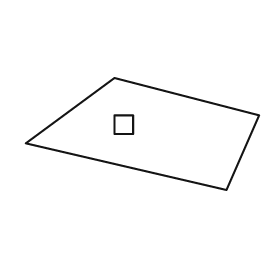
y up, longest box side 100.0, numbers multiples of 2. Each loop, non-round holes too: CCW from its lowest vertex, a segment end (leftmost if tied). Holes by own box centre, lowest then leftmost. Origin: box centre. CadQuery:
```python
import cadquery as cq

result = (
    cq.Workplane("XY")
    .moveTo(36.0, -24.0)
    .lineTo(50.0, 8.0)
    .lineTo(-12.0, 24.0)
    .lineTo(-50.0, -4.0)
    .close()
    .moveTo(-12.0, 0.0)
    .lineTo(-4.0, 0.0)
    .lineTo(-4.0, 8.0)
    .lineTo(-12.0, 8.0)
    .close()
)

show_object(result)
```